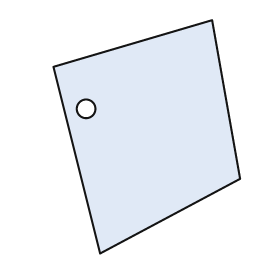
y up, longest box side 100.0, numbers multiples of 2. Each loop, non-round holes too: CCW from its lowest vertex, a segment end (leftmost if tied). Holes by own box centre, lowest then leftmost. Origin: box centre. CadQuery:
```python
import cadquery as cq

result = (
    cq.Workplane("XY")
    .moveTo(-20.0, -50.0)
    .lineTo(40.0, -18.0)
    .lineTo(28.0, 50.0)
    .lineTo(-40.0, 30.0)
    .close()
    .moveTo(-26.0, 12.0)
    .circle(4.0)
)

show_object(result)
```